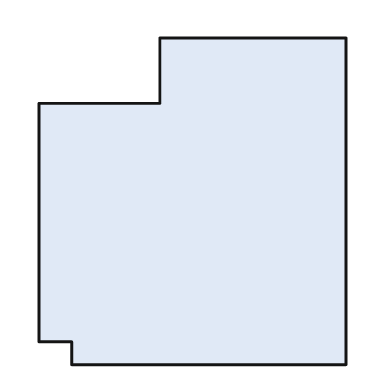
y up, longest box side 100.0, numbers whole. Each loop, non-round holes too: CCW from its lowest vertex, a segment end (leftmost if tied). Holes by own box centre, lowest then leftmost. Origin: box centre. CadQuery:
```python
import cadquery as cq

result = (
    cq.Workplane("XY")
    .moveTo(-37.0, -50.0)
    .lineTo(47.0, -50.0)
    .lineTo(47.0, 50.0)
    .lineTo(-10.0, 50.0)
    .lineTo(-10.0, 30.0)
    .lineTo(-47.0, 30.0)
    .lineTo(-47.0, -43.0)
    .lineTo(-37.0, -43.0)
    .close()
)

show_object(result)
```